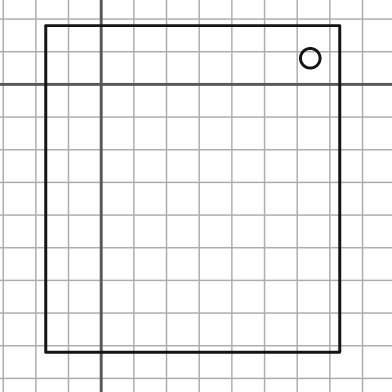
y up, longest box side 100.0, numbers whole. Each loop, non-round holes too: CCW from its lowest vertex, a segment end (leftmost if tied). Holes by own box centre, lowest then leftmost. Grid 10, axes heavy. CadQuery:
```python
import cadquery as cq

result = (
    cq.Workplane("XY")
    .moveTo(-17.0, -82.0)
    .lineTo(73.0, -82.0)
    .lineTo(73.0, 18.0)
    .lineTo(-17.0, 18.0)
    .close()
    .moveTo(64.0, 8.0)
    .circle(3.0)
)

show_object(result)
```